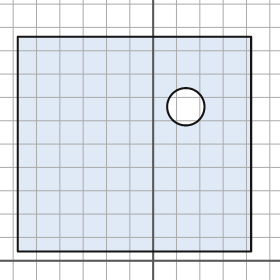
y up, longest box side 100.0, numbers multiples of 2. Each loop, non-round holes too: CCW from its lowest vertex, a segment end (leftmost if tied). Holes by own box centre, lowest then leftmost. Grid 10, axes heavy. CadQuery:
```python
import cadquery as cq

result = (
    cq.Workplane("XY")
    .moveTo(-58.0, 4.0)
    .lineTo(42.0, 4.0)
    .lineTo(42.0, 96.0)
    .lineTo(-58.0, 96.0)
    .close()
    .moveTo(14.0, 66.0)
    .circle(8.0)
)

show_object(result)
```